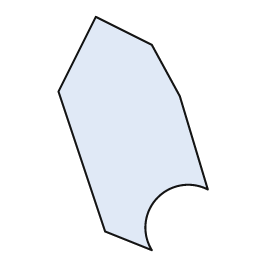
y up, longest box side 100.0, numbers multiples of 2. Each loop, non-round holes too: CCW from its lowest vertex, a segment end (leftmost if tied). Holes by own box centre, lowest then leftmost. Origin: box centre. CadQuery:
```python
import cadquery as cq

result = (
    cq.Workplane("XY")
    .moveTo(8.0, -50.0)
    .threePointArc((10.0, -28.0), (32.0, -24.0))
    .lineTo(20.0, 16.0)
    .lineTo(8.0, 38.0)
    .lineTo(-16.0, 50.0)
    .lineTo(-32.0, 18.0)
    .lineTo(-12.0, -42.0)
    .close()
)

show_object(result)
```